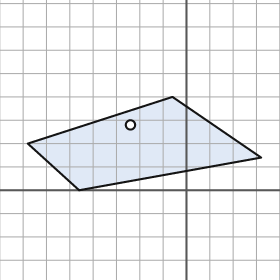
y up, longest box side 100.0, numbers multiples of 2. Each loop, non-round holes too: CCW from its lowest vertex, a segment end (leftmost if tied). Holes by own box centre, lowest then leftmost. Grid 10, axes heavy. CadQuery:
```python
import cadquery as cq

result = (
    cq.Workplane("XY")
    .moveTo(-46.0, 0.0)
    .lineTo(32.0, 14.0)
    .lineTo(-6.0, 40.0)
    .lineTo(-68.0, 20.0)
    .close()
    .moveTo(-24.0, 28.0)
    .circle(2.0)
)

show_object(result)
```